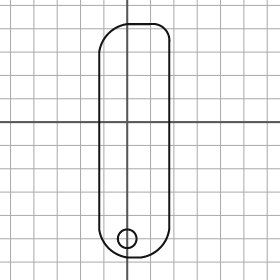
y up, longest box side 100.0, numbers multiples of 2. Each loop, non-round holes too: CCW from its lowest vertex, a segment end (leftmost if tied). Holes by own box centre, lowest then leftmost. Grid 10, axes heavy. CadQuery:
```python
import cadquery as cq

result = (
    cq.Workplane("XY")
    .moveTo(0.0, -58.0)
    .lineTo(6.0, -58.0)
    .threePointArc((14.0, -54.0), (18.0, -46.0))
    .lineTo(18.0, 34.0)
    .threePointArc((16.0, 40.0), (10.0, 42.0))
    .lineTo(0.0, 42.0)
    .threePointArc((-8.0, 38.0), (-12.0, 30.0))
    .lineTo(-12.0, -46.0)
    .threePointArc((-8.0, -54.0), (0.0, -58.0))
    .close()
    .moveTo(0.0, -50.0)
    .circle(4.0)
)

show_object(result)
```